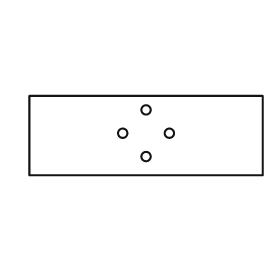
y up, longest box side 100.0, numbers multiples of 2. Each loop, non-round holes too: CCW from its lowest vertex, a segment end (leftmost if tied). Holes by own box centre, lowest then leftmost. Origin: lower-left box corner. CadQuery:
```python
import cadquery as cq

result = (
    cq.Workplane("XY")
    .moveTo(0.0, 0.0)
    .lineTo(100.0, 0.0)
    .lineTo(100.0, 34.0)
    .lineTo(0.0, 34.0)
    .close()
    .moveTo(50.0, 8.0)
    .circle(2.0)
    .moveTo(40.0, 18.0)
    .circle(2.0)
    .moveTo(60.0, 18.0)
    .circle(2.0)
    .moveTo(50.0, 28.0)
    .circle(2.0)
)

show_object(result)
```